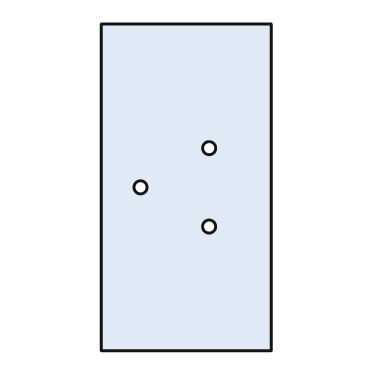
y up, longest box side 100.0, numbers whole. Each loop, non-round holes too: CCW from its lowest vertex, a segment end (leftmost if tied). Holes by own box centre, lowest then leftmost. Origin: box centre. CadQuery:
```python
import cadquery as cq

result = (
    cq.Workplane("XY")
    .moveTo(-26.0, -50.0)
    .lineTo(26.0, -50.0)
    .lineTo(26.0, 50.0)
    .lineTo(-26.0, 50.0)
    .close()
    .moveTo(7.0, -12.0)
    .circle(2.0)
    .moveTo(-14.0, 0.0)
    .circle(2.0)
    .moveTo(7.0, 12.0)
    .circle(2.0)
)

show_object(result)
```